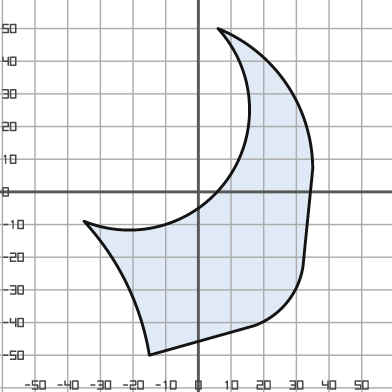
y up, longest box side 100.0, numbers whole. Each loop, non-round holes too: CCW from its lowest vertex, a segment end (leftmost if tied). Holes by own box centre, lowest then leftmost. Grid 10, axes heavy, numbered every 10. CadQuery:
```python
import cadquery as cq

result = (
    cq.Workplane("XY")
    .moveTo(-15.0, -50.0)
    .lineTo(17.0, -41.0)
    .threePointArc((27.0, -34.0), (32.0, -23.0))
    .lineTo(35.0, 7.0)
    .threePointArc((27.0, 33.0), (6.0, 50.0))
    .threePointArc((9.0, 4.0), (-35.0, -9.0))
    .threePointArc((-22.0, -28.0), (-15.0, -50.0))
    .close()
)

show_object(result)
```